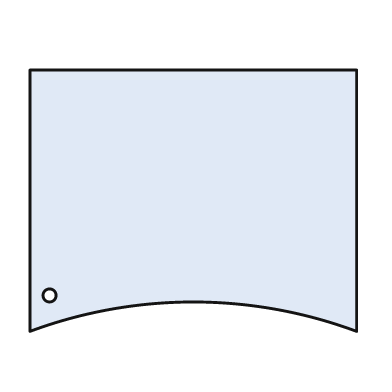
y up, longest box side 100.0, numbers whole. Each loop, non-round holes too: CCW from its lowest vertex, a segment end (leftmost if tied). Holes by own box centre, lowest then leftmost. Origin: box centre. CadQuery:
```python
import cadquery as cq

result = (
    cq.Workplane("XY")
    .moveTo(-50.0, -40.0)
    .threePointArc((0.0, -31.0), (50.0, -40.0))
    .lineTo(50.0, 40.0)
    .lineTo(-50.0, 40.0)
    .close()
    .moveTo(-44.0, -29.0)
    .circle(2.0)
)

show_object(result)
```